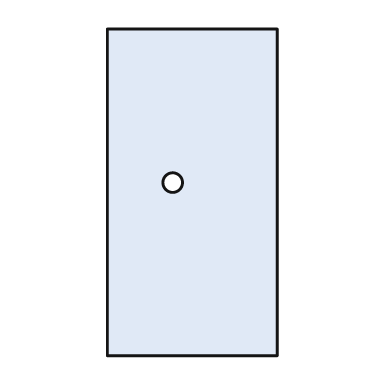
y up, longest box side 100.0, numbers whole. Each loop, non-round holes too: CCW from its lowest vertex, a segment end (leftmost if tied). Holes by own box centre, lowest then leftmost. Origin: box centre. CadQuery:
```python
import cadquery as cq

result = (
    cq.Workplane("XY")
    .moveTo(-26.0, -50.0)
    .lineTo(26.0, -50.0)
    .lineTo(26.0, 50.0)
    .lineTo(-26.0, 50.0)
    .close()
    .moveTo(-6.0, 3.0)
    .circle(3.0)
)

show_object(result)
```